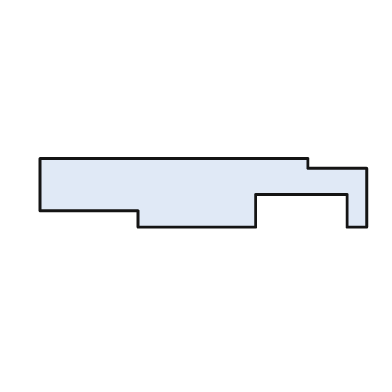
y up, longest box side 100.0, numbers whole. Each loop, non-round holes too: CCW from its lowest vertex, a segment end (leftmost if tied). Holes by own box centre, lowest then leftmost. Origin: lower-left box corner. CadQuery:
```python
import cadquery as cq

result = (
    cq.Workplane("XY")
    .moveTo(30.0, 0.0)
    .lineTo(66.0, 0.0)
    .lineTo(66.0, 10.0)
    .lineTo(94.0, 10.0)
    .lineTo(94.0, 0.0)
    .lineTo(100.0, 0.0)
    .lineTo(100.0, 18.0)
    .lineTo(82.0, 18.0)
    .lineTo(82.0, 21.0)
    .lineTo(0.0, 21.0)
    .lineTo(0.0, 5.0)
    .lineTo(30.0, 5.0)
    .close()
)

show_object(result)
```